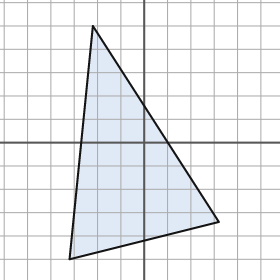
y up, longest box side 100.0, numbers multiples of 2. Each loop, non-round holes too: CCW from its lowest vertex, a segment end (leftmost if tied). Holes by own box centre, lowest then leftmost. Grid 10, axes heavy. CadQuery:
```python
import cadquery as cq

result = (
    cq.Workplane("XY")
    .moveTo(-32.0, -50.0)
    .lineTo(32.0, -34.0)
    .lineTo(-22.0, 50.0)
    .close()
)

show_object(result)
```